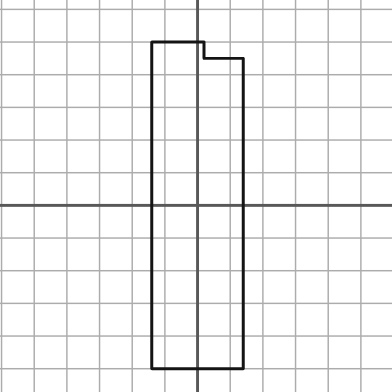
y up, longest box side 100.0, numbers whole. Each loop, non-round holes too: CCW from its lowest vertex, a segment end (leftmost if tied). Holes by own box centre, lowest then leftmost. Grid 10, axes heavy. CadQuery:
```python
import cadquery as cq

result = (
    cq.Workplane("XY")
    .moveTo(-14.0, -50.0)
    .lineTo(14.0, -50.0)
    .lineTo(14.0, 45.0)
    .lineTo(2.0, 45.0)
    .lineTo(2.0, 50.0)
    .lineTo(-14.0, 50.0)
    .close()
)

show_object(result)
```